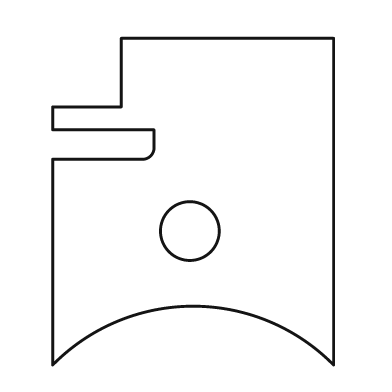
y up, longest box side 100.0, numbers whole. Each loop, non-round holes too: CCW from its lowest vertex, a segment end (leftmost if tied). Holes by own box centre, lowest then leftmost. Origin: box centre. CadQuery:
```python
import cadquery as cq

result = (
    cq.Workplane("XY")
    .moveTo(-43.0, -50.0)
    .threePointArc((0.0, -32.0), (43.0, -50.0))
    .lineTo(43.0, 50.0)
    .lineTo(-22.0, 50.0)
    .lineTo(-22.0, 29.0)
    .lineTo(-43.0, 29.0)
    .lineTo(-43.0, 22.0)
    .lineTo(-12.0, 22.0)
    .lineTo(-12.0, 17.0)
    .threePointArc((-13.0, 14.0), (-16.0, 13.0))
    .lineTo(-43.0, 13.0)
    .close()
    .moveTo(-1.0, -9.0)
    .circle(9.0)
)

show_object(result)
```